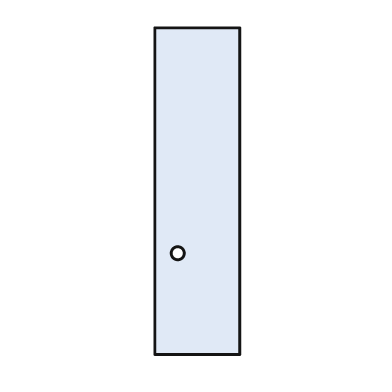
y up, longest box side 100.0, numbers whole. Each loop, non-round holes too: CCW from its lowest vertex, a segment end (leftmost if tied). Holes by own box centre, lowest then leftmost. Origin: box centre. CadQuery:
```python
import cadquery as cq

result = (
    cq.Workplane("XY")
    .moveTo(-13.0, -50.0)
    .lineTo(13.0, -50.0)
    .lineTo(13.0, 50.0)
    .lineTo(-13.0, 50.0)
    .close()
    .moveTo(-6.0, -19.0)
    .circle(2.0)
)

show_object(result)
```